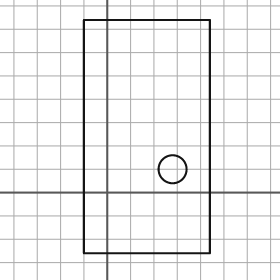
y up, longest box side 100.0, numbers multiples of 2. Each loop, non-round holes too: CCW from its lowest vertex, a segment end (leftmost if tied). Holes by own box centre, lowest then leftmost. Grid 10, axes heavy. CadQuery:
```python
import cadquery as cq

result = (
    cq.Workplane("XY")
    .moveTo(-10.0, -26.0)
    .lineTo(44.0, -26.0)
    .lineTo(44.0, 74.0)
    .lineTo(-10.0, 74.0)
    .close()
    .moveTo(28.0, 10.0)
    .circle(6.0)
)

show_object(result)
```